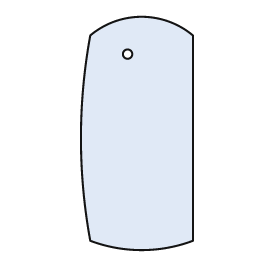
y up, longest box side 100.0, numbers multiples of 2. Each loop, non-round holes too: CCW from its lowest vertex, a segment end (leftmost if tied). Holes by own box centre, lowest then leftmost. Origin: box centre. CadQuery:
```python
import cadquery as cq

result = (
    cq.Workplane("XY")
    .moveTo(-20.0, -46.0)
    .threePointArc((2.0, -50.0), (24.0, -46.0))
    .lineTo(24.0, 42.0)
    .threePointArc((2.0, 50.0), (-20.0, 42.0))
    .threePointArc((-24.0, -2.0), (-20.0, -46.0))
    .close()
    .moveTo(-4.0, 34.0)
    .circle(2.0)
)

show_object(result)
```